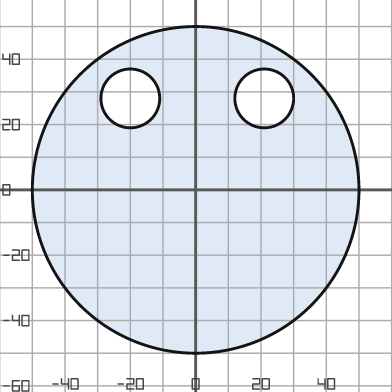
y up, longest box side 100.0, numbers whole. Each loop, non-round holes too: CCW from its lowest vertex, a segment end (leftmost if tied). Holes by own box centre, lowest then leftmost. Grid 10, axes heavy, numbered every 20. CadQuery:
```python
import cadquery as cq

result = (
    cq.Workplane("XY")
    .moveTo(0.0, 0.0)
    .circle(50.0)
    .moveTo(-20.0, 28.0)
    .circle(9.0)
    .moveTo(21.0, 28.0)
    .circle(9.0)
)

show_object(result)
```